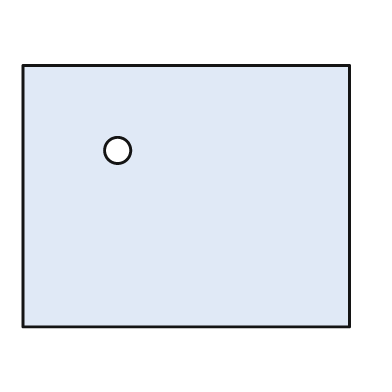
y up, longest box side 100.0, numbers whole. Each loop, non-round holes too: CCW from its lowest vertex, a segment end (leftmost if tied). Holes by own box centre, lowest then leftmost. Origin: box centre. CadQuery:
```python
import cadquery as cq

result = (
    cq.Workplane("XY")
    .moveTo(-50.0, -40.0)
    .lineTo(50.0, -40.0)
    .lineTo(50.0, 40.0)
    .lineTo(-50.0, 40.0)
    .close()
    .moveTo(-21.0, 14.0)
    .circle(4.0)
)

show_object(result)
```